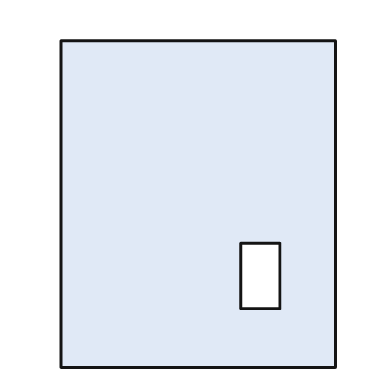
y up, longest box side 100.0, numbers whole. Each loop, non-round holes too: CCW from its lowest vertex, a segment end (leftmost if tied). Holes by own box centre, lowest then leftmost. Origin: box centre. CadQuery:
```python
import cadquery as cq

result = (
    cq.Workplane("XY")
    .moveTo(-42.0, -50.0)
    .lineTo(42.0, -50.0)
    .lineTo(42.0, 50.0)
    .lineTo(-42.0, 50.0)
    .close()
    .moveTo(13.0, -32.0)
    .lineTo(25.0, -32.0)
    .lineTo(25.0, -12.0)
    .lineTo(13.0, -12.0)
    .close()
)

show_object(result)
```